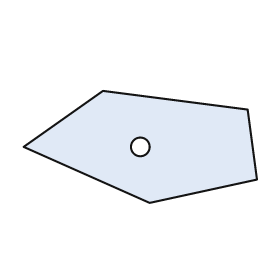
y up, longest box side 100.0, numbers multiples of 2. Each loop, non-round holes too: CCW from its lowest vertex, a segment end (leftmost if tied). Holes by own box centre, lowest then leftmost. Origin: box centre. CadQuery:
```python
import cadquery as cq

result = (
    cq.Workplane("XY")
    .moveTo(4.0, -24.0)
    .lineTo(50.0, -14.0)
    .lineTo(46.0, 16.0)
    .lineTo(-16.0, 24.0)
    .lineTo(-50.0, 0.0)
    .close()
    .moveTo(0.0, 0.0)
    .circle(4.0)
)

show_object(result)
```